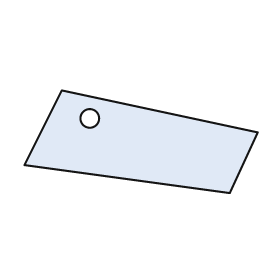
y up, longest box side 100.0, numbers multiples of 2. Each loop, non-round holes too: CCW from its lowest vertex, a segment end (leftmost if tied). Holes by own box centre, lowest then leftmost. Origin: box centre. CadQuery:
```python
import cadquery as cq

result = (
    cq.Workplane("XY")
    .moveTo(38.0, -22.0)
    .lineTo(50.0, 4.0)
    .lineTo(-34.0, 22.0)
    .lineTo(-50.0, -10.0)
    .close()
    .moveTo(-22.0, 10.0)
    .circle(4.0)
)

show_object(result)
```